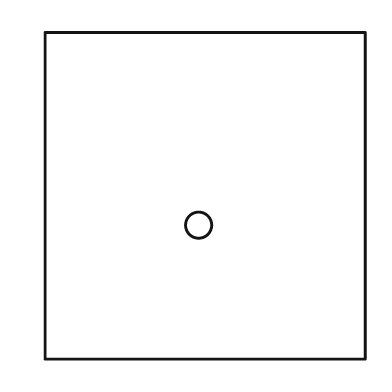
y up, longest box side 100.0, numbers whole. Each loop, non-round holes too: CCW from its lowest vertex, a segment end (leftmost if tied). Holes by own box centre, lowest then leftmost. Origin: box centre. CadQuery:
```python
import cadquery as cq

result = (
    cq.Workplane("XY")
    .moveTo(-49.0, -50.0)
    .lineTo(49.0, -50.0)
    .lineTo(49.0, 50.0)
    .lineTo(-49.0, 50.0)
    .close()
    .moveTo(-2.0, -9.0)
    .circle(4.0)
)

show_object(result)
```